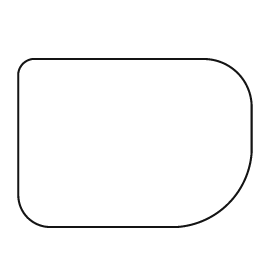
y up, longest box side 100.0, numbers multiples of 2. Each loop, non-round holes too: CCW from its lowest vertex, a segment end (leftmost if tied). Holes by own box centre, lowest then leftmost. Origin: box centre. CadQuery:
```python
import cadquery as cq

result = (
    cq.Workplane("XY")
    .moveTo(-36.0, -36.0)
    .lineTo(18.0, -36.0)
    .threePointArc((40.0, -26.0), (50.0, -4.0))
    .lineTo(50.0, 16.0)
    .threePointArc((44.0, 30.0), (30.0, 36.0))
    .lineTo(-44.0, 36.0)
    .threePointArc((-48.0, 34.0), (-50.0, 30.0))
    .lineTo(-50.0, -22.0)
    .threePointArc((-46.0, -32.0), (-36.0, -36.0))
    .close()
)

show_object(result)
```